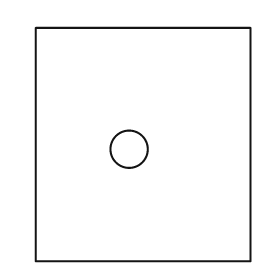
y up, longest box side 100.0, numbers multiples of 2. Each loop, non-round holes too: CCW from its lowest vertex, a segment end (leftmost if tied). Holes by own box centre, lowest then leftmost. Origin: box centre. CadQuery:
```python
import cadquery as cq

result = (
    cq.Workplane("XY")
    .moveTo(-46.0, -50.0)
    .lineTo(46.0, -50.0)
    .lineTo(46.0, 50.0)
    .lineTo(-46.0, 50.0)
    .close()
    .moveTo(-6.0, -2.0)
    .circle(8.0)
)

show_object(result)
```